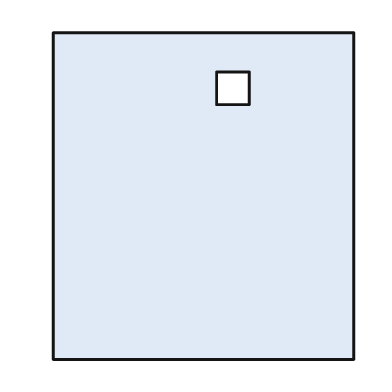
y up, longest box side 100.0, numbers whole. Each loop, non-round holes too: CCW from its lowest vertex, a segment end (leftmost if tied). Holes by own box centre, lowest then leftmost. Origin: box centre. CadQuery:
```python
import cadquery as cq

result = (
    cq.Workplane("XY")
    .moveTo(-46.0, -50.0)
    .lineTo(46.0, -50.0)
    .lineTo(46.0, 50.0)
    .lineTo(-46.0, 50.0)
    .close()
    .moveTo(4.0, 28.0)
    .lineTo(14.0, 28.0)
    .lineTo(14.0, 38.0)
    .lineTo(4.0, 38.0)
    .close()
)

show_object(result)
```